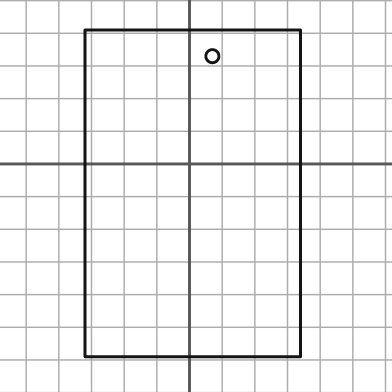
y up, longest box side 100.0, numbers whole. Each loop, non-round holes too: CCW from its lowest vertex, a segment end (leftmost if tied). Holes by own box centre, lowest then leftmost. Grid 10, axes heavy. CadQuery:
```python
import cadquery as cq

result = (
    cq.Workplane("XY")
    .moveTo(-32.0, -59.0)
    .lineTo(34.0, -59.0)
    .lineTo(34.0, 41.0)
    .lineTo(-32.0, 41.0)
    .close()
    .moveTo(7.0, 33.0)
    .circle(2.0)
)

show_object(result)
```